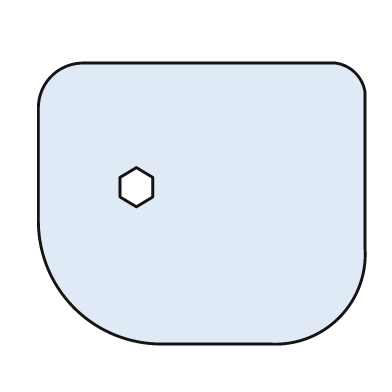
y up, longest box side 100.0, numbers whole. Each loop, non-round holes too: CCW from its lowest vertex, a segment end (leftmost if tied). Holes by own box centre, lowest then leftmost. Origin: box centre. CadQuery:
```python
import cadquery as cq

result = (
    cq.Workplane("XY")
    .moveTo(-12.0, -43.0)
    .lineTo(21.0, -43.0)
    .threePointArc((42.0, -35.0), (50.0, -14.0))
    .lineTo(50.0, 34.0)
    .threePointArc((47.0, 40.0), (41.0, 43.0))
    .lineTo(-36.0, 43.0)
    .threePointArc((-46.0, 39.0), (-50.0, 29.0))
    .lineTo(-50.0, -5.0)
    .threePointArc((-39.0, -32.0), (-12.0, -43.0))
    .close()
    .moveTo(-20.0, -1.0)
    .lineTo(-15.0, 2.0)
    .lineTo(-15.0, 8.0)
    .lineTo(-20.0, 11.0)
    .lineTo(-25.0, 8.0)
    .lineTo(-25.0, 2.0)
    .close()
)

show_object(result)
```